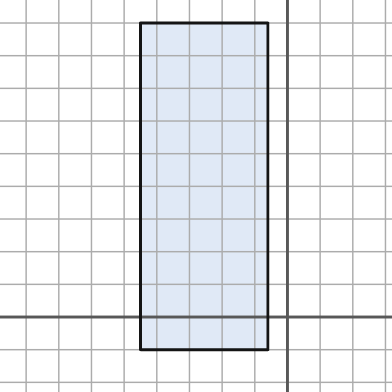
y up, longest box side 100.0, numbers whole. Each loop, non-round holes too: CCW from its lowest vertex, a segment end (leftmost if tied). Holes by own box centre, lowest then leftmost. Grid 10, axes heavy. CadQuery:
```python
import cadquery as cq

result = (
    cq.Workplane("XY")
    .moveTo(-45.0, -10.0)
    .lineTo(-6.0, -10.0)
    .lineTo(-6.0, 90.0)
    .lineTo(-45.0, 90.0)
    .close()
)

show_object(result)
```